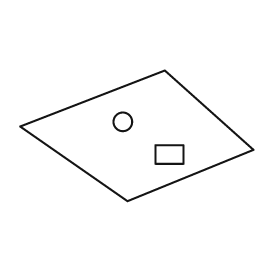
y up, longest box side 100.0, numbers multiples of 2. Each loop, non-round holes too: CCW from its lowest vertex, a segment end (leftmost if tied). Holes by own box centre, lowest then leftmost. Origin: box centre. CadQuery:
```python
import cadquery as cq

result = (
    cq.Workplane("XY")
    .moveTo(-4.0, -28.0)
    .lineTo(50.0, -6.0)
    .lineTo(12.0, 28.0)
    .lineTo(-50.0, 4.0)
    .close()
    .moveTo(8.0, -12.0)
    .lineTo(20.0, -12.0)
    .lineTo(20.0, -4.0)
    .lineTo(8.0, -4.0)
    .close()
    .moveTo(-6.0, 6.0)
    .circle(4.0)
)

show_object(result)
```